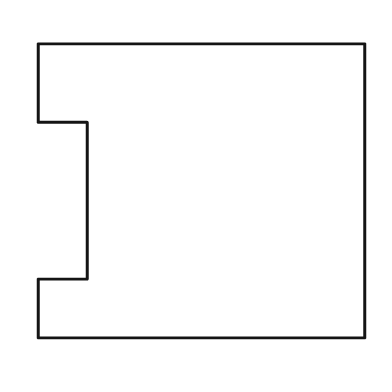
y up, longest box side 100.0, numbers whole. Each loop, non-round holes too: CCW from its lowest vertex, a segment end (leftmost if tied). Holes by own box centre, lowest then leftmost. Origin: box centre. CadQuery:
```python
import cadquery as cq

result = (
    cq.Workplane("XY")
    .moveTo(-50.0, -45.0)
    .lineTo(50.0, -45.0)
    .lineTo(50.0, 45.0)
    .lineTo(-50.0, 45.0)
    .lineTo(-50.0, 21.0)
    .lineTo(-35.0, 21.0)
    .lineTo(-35.0, -27.0)
    .lineTo(-50.0, -27.0)
    .close()
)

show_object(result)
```